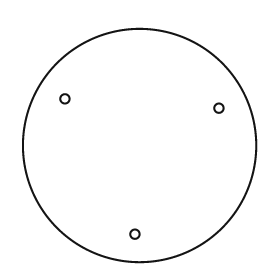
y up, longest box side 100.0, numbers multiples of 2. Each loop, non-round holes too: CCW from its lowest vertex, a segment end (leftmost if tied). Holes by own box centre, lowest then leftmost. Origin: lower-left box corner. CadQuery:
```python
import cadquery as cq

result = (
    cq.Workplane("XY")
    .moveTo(50.0, 50.0)
    .circle(50.0)
    .moveTo(48.0, 12.0)
    .circle(2.0)
    .moveTo(84.0, 66.0)
    .circle(2.0)
    .moveTo(18.0, 70.0)
    .circle(2.0)
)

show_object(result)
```